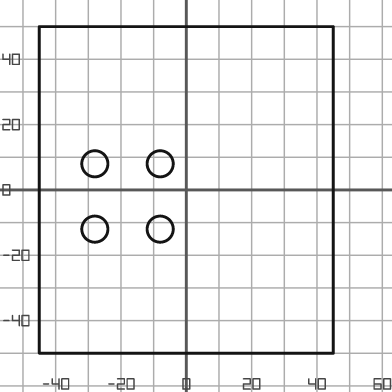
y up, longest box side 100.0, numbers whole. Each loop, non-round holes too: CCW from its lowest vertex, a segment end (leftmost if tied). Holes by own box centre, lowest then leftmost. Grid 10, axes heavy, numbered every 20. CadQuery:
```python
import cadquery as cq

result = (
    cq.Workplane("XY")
    .moveTo(-45.0, -50.0)
    .lineTo(45.0, -50.0)
    .lineTo(45.0, 50.0)
    .lineTo(-45.0, 50.0)
    .close()
    .moveTo(-28.0, -12.0)
    .circle(4.0)
    .moveTo(-8.0, -12.0)
    .circle(4.0)
    .moveTo(-28.0, 8.0)
    .circle(4.0)
    .moveTo(-8.0, 8.0)
    .circle(4.0)
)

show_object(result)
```